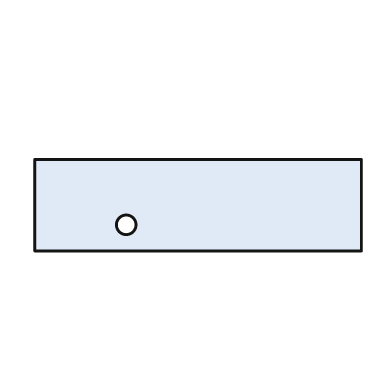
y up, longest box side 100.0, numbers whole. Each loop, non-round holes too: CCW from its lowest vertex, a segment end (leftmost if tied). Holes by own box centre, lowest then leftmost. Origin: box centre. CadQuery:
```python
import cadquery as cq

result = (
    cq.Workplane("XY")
    .moveTo(-50.0, -14.0)
    .lineTo(50.0, -14.0)
    .lineTo(50.0, 14.0)
    .lineTo(-50.0, 14.0)
    .close()
    .moveTo(-22.0, -6.0)
    .circle(3.0)
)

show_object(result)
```